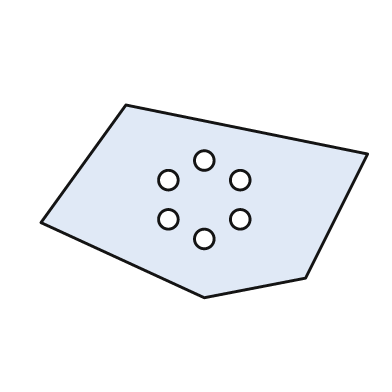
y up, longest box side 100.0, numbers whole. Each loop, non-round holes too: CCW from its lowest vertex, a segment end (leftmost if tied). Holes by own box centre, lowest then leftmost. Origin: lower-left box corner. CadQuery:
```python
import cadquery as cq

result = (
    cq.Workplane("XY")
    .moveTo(50.0, 0.0)
    .lineTo(81.0, 6.0)
    .lineTo(100.0, 44.0)
    .lineTo(26.0, 59.0)
    .lineTo(0.0, 23.0)
    .close()
    .moveTo(50.0, 18.0)
    .circle(3.0)
    .moveTo(39.0, 24.0)
    .circle(3.0)
    .moveTo(61.0, 24.0)
    .circle(3.0)
    .moveTo(39.0, 36.0)
    .circle(3.0)
    .moveTo(61.0, 36.0)
    .circle(3.0)
    .moveTo(50.0, 42.0)
    .circle(3.0)
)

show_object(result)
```